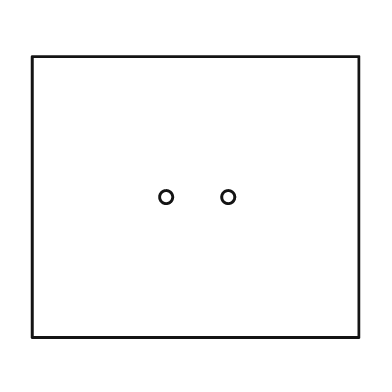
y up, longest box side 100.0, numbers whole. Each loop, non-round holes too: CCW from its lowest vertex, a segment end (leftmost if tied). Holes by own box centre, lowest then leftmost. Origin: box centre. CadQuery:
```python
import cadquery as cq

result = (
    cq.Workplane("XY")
    .moveTo(-50.0, -43.0)
    .lineTo(50.0, -43.0)
    .lineTo(50.0, 43.0)
    .lineTo(-50.0, 43.0)
    .close()
    .moveTo(-9.0, 0.0)
    .circle(2.0)
    .moveTo(10.0, 0.0)
    .circle(2.0)
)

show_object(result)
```